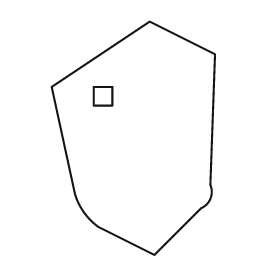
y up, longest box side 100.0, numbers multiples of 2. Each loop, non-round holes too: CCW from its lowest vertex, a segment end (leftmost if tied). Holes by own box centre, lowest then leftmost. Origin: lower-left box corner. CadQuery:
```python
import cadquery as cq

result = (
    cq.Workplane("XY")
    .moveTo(44.0, 0.0)
    .lineTo(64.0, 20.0)
    .threePointArc((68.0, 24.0), (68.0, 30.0))
    .lineTo(70.0, 86.0)
    .lineTo(42.0, 100.0)
    .lineTo(0.0, 72.0)
    .lineTo(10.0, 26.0)
    .threePointArc((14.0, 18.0), (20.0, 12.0))
    .close()
    .moveTo(18.0, 64.0)
    .lineTo(26.0, 64.0)
    .lineTo(26.0, 72.0)
    .lineTo(18.0, 72.0)
    .close()
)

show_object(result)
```